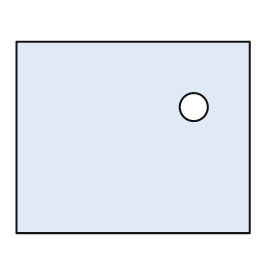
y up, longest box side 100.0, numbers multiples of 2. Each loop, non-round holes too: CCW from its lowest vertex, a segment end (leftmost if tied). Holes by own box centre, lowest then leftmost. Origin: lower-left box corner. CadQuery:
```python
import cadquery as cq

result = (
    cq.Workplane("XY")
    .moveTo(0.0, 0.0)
    .lineTo(100.0, 0.0)
    .lineTo(100.0, 82.0)
    .lineTo(0.0, 82.0)
    .close()
    .moveTo(76.0, 54.0)
    .circle(6.0)
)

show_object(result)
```